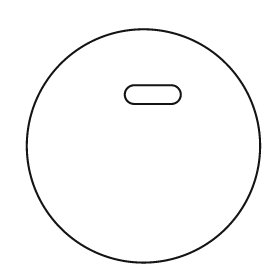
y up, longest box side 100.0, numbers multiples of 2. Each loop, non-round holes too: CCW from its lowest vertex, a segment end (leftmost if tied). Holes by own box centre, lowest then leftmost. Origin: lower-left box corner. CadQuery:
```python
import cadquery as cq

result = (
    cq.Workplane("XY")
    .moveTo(50.0, 50.0)
    .circle(50.0)
    .moveTo(46.0, 68.0)
    .lineTo(62.0, 68.0)
    .threePointArc((66.0, 72.0), (62.0, 76.0))
    .lineTo(46.0, 76.0)
    .threePointArc((42.0, 72.0), (46.0, 68.0))
    .close()
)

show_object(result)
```